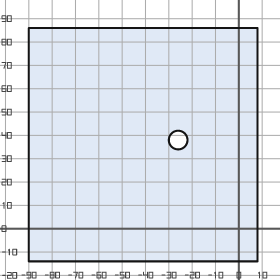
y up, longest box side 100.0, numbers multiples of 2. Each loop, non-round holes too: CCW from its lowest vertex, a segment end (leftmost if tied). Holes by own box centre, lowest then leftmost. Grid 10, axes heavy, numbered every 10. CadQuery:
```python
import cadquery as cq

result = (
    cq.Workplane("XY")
    .moveTo(-90.0, -14.0)
    .lineTo(8.0, -14.0)
    .lineTo(8.0, 86.0)
    .lineTo(-90.0, 86.0)
    .close()
    .moveTo(-26.0, 38.0)
    .circle(4.0)
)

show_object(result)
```